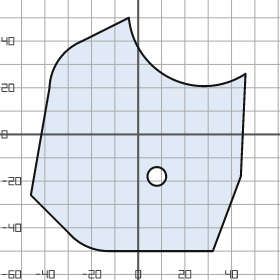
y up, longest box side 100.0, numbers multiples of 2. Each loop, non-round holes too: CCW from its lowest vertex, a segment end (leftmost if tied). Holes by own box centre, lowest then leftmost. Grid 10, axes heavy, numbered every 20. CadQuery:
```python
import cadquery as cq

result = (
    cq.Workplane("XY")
    .moveTo(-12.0, -50.0)
    .lineTo(32.0, -50.0)
    .lineTo(44.0, -18.0)
    .lineTo(46.0, 26.0)
    .threePointArc((14.0, 24.0), (-4.0, 50.0))
    .lineTo(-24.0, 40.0)
    .threePointArc((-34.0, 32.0), (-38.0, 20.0))
    .lineTo(-46.0, -26.0)
    .lineTo(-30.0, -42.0)
    .threePointArc((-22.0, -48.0), (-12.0, -50.0))
    .close()
    .moveTo(8.0, -18.0)
    .circle(4.0)
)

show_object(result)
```